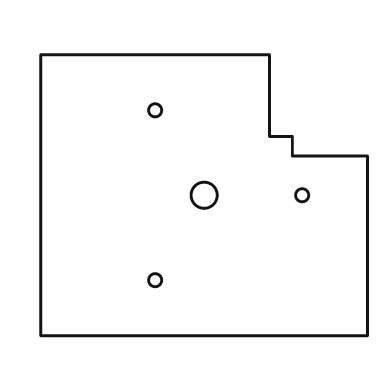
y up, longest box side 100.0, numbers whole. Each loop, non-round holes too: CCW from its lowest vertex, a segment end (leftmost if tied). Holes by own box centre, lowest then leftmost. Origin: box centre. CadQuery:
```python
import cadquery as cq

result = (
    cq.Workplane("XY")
    .moveTo(-50.0, -43.0)
    .lineTo(50.0, -43.0)
    .lineTo(50.0, 12.0)
    .lineTo(27.0, 12.0)
    .lineTo(27.0, 18.0)
    .lineTo(20.0, 18.0)
    .lineTo(20.0, 43.0)
    .lineTo(-50.0, 43.0)
    .close()
    .moveTo(-15.0, -26.0)
    .circle(2.0)
    .moveTo(0.0, 0.0)
    .circle(4.0)
    .moveTo(30.0, 0.0)
    .circle(2.0)
    .moveTo(-15.0, 26.0)
    .circle(2.0)
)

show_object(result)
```